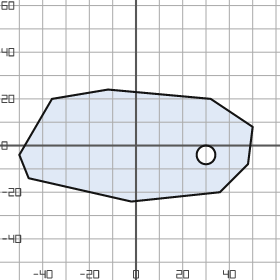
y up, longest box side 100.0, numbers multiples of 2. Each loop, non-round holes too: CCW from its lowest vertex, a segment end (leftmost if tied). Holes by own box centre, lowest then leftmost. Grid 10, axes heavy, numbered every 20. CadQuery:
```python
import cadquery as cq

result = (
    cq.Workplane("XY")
    .moveTo(-2.0, -24.0)
    .lineTo(36.0, -20.0)
    .lineTo(48.0, -8.0)
    .lineTo(50.0, 8.0)
    .lineTo(32.0, 20.0)
    .lineTo(-12.0, 24.0)
    .lineTo(-36.0, 20.0)
    .lineTo(-50.0, -4.0)
    .lineTo(-46.0, -14.0)
    .close()
    .moveTo(30.0, -4.0)
    .circle(4.0)
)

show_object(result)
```